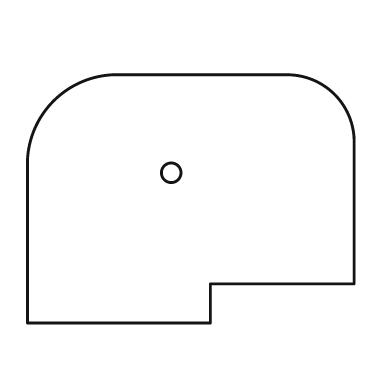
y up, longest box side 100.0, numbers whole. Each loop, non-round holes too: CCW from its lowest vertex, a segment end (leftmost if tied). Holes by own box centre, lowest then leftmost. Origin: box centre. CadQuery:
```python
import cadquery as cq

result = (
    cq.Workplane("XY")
    .moveTo(-50.0, -38.0)
    .lineTo(6.0, -38.0)
    .lineTo(6.0, -26.0)
    .lineTo(50.0, -26.0)
    .lineTo(50.0, 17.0)
    .threePointArc((44.0, 32.0), (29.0, 38.0))
    .lineTo(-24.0, 38.0)
    .threePointArc((-42.0, 30.0), (-50.0, 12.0))
    .close()
    .moveTo(-6.0, 8.0)
    .circle(3.0)
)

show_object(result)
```